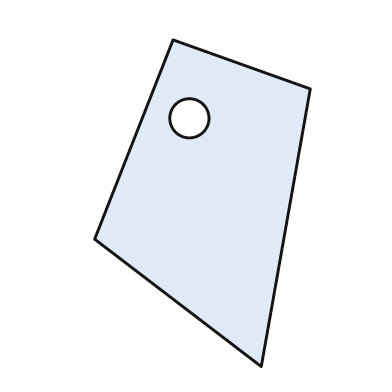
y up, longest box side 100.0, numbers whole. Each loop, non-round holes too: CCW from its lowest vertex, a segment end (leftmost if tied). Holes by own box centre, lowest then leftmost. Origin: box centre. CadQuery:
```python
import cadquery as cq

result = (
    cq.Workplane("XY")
    .moveTo(18.0, -50.0)
    .lineTo(33.0, 35.0)
    .lineTo(-9.0, 50.0)
    .lineTo(-33.0, -11.0)
    .close()
    .moveTo(-4.0, 26.0)
    .circle(6.0)
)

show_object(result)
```